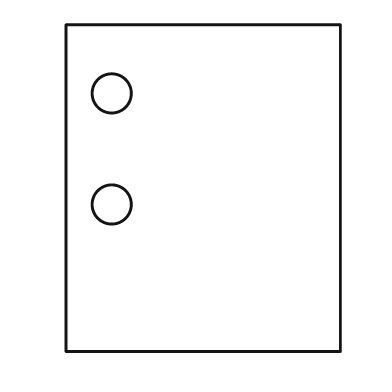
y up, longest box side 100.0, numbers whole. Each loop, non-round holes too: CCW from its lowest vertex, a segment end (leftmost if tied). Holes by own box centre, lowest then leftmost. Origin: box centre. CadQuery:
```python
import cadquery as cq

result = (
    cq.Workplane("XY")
    .moveTo(-42.0, -50.0)
    .lineTo(42.0, -50.0)
    .lineTo(42.0, 50.0)
    .lineTo(-42.0, 50.0)
    .close()
    .moveTo(-28.0, -5.0)
    .circle(6.0)
    .moveTo(-28.0, 29.0)
    .circle(6.0)
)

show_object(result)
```